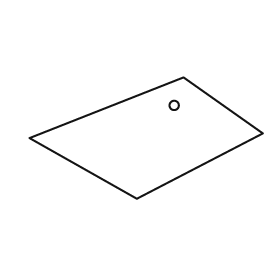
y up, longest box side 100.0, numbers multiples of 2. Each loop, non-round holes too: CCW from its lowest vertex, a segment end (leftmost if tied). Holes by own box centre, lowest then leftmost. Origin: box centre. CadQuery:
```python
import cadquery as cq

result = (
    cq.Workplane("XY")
    .moveTo(-4.0, -26.0)
    .lineTo(50.0, 2.0)
    .lineTo(16.0, 26.0)
    .lineTo(-50.0, 0.0)
    .close()
    .moveTo(12.0, 14.0)
    .circle(2.0)
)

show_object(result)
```